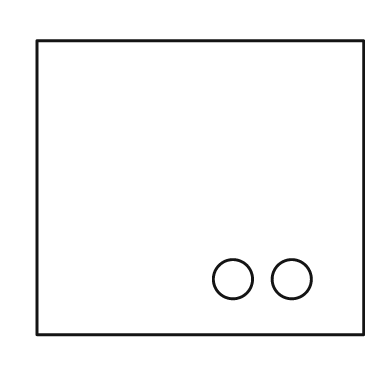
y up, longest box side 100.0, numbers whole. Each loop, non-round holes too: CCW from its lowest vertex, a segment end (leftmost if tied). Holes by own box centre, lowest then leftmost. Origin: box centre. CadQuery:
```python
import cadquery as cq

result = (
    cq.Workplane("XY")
    .moveTo(-50.0, -45.0)
    .lineTo(50.0, -45.0)
    .lineTo(50.0, 45.0)
    .lineTo(-50.0, 45.0)
    .close()
    .moveTo(10.0, -28.0)
    .circle(6.0)
    .moveTo(28.0, -28.0)
    .circle(6.0)
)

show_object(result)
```